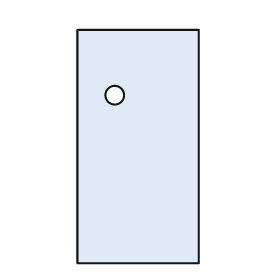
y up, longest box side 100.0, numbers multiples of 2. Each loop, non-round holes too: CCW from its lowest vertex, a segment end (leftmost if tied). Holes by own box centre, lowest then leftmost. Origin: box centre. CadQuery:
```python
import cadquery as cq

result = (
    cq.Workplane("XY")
    .moveTo(-26.0, -50.0)
    .lineTo(26.0, -50.0)
    .lineTo(26.0, 50.0)
    .lineTo(-26.0, 50.0)
    .close()
    .moveTo(-10.0, 22.0)
    .circle(4.0)
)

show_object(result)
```